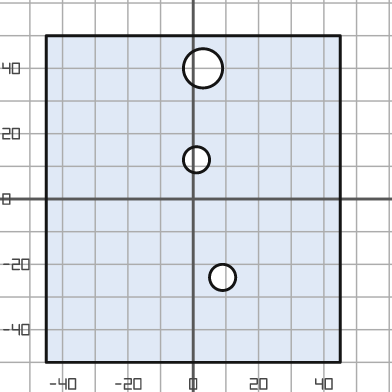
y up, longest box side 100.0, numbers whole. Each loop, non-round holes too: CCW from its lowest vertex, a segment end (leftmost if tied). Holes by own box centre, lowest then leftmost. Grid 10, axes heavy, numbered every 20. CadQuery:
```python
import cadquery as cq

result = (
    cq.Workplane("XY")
    .moveTo(-45.0, -50.0)
    .lineTo(45.0, -50.0)
    .lineTo(45.0, 50.0)
    .lineTo(-45.0, 50.0)
    .close()
    .moveTo(9.0, -24.0)
    .circle(4.0)
    .moveTo(1.0, 12.0)
    .circle(4.0)
    .moveTo(3.0, 40.0)
    .circle(6.0)
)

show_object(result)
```